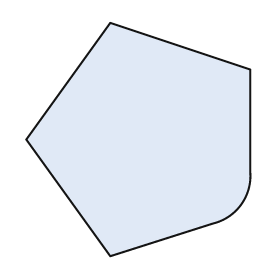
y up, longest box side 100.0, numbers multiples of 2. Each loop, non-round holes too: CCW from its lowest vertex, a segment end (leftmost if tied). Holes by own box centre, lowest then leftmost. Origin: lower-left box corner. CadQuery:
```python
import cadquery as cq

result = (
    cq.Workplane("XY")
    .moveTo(36.0, 0.0)
    .lineTo(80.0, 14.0)
    .threePointArc((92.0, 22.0), (96.0, 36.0))
    .lineTo(96.0, 80.0)
    .lineTo(36.0, 100.0)
    .lineTo(0.0, 50.0)
    .close()
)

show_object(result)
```